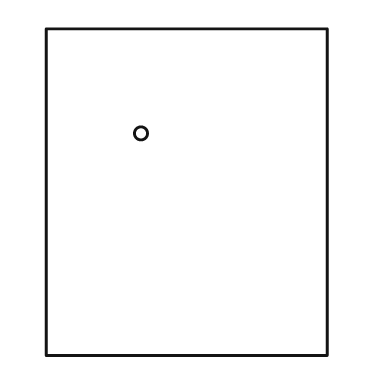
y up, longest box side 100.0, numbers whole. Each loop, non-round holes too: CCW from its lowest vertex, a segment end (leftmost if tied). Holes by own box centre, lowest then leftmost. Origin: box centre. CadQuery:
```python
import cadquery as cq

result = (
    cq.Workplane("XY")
    .moveTo(-43.0, -50.0)
    .lineTo(43.0, -50.0)
    .lineTo(43.0, 50.0)
    .lineTo(-43.0, 50.0)
    .close()
    .moveTo(-14.0, 18.0)
    .circle(2.0)
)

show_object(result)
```